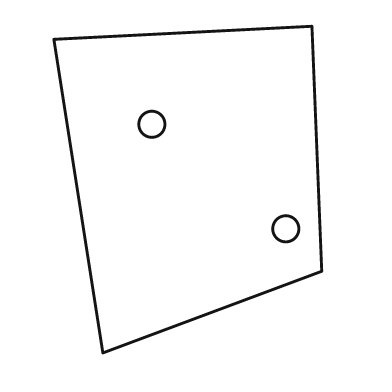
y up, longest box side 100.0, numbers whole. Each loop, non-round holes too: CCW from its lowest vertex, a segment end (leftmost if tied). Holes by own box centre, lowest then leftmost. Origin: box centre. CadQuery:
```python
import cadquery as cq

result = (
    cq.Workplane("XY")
    .moveTo(-26.0, -50.0)
    .lineTo(41.0, -25.0)
    .lineTo(38.0, 50.0)
    .lineTo(-41.0, 46.0)
    .close()
    .moveTo(30.0, -12.0)
    .circle(4.0)
    .moveTo(-11.0, 20.0)
    .circle(4.0)
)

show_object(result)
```